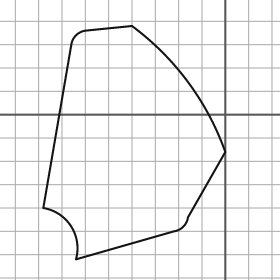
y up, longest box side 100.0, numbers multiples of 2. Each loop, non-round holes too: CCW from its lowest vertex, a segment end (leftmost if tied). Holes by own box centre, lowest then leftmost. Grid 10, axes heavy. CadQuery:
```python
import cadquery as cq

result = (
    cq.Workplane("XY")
    .moveTo(-64.0, -62.0)
    .lineTo(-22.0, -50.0)
    .threePointArc((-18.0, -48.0), (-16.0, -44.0))
    .lineTo(0.0, -16.0)
    .threePointArc((-16.0, 14.0), (-40.0, 38.0))
    .lineTo(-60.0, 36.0)
    .threePointArc((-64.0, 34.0), (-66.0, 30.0))
    .lineTo(-78.0, -40.0)
    .threePointArc((-66.0, -48.0), (-64.0, -62.0))
    .close()
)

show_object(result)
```